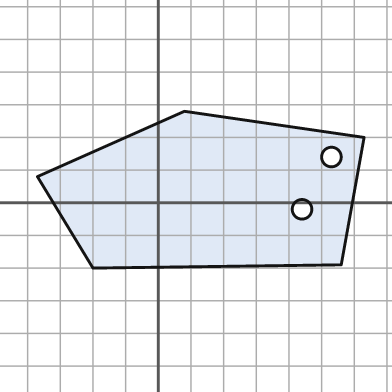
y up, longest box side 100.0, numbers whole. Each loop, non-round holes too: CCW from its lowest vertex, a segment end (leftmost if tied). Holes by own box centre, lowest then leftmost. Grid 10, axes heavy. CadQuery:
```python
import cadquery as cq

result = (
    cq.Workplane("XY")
    .moveTo(-20.0, -20.0)
    .lineTo(56.0, -19.0)
    .lineTo(63.0, 20.0)
    .lineTo(8.0, 28.0)
    .lineTo(-37.0, 8.0)
    .close()
    .moveTo(44.0, -2.0)
    .circle(3.0)
    .moveTo(53.0, 14.0)
    .circle(3.0)
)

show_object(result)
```